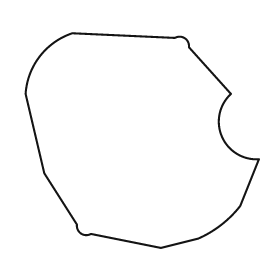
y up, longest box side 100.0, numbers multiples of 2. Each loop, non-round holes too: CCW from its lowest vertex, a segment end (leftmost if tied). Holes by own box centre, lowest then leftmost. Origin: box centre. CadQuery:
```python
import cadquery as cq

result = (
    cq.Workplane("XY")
    .moveTo(8.0, -46.0)
    .lineTo(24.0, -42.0)
    .threePointArc((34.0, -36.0), (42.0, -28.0))
    .lineTo(50.0, -8.0)
    .threePointArc((34.0, 2.0), (38.0, 20.0))
    .lineTo(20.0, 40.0)
    .threePointArc((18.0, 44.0), (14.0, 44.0))
    .lineTo(-30.0, 46.0)
    .threePointArc((-44.0, 36.0), (-50.0, 20.0))
    .lineTo(-42.0, -14.0)
    .lineTo(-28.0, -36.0)
    .threePointArc((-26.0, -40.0), (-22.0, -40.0))
    .close()
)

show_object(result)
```